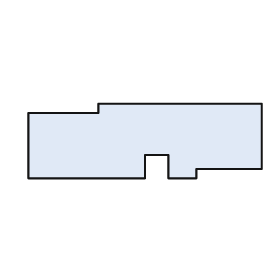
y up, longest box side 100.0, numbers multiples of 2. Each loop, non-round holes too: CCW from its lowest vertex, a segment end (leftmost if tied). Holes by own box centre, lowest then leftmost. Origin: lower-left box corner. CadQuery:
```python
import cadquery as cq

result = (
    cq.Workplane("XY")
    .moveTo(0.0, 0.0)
    .lineTo(50.0, 0.0)
    .lineTo(50.0, 10.0)
    .lineTo(60.0, 10.0)
    .lineTo(60.0, 0.0)
    .lineTo(72.0, 0.0)
    .lineTo(72.0, 4.0)
    .lineTo(100.0, 4.0)
    .lineTo(100.0, 32.0)
    .lineTo(30.0, 32.0)
    .lineTo(30.0, 28.0)
    .lineTo(0.0, 28.0)
    .close()
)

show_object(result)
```